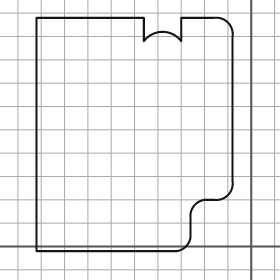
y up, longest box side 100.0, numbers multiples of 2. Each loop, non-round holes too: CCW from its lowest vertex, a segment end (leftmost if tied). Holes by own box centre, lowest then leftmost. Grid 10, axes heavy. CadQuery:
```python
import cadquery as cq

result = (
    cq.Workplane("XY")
    .moveTo(-92.0, -2.0)
    .lineTo(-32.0, -2.0)
    .threePointArc((-28.0, 0.0), (-26.0, 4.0))
    .lineTo(-26.0, 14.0)
    .threePointArc((-24.0, 18.0), (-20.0, 20.0))
    .lineTo(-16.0, 20.0)
    .threePointArc((-10.0, 22.0), (-8.0, 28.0))
    .lineTo(-8.0, 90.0)
    .threePointArc((-10.0, 96.0), (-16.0, 98.0))
    .lineTo(-30.0, 98.0)
    .lineTo(-30.0, 88.0)
    .threePointArc((-38.0, 92.0), (-46.0, 88.0))
    .lineTo(-46.0, 98.0)
    .lineTo(-92.0, 98.0)
    .close()
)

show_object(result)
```